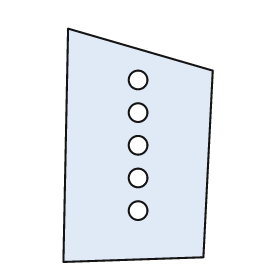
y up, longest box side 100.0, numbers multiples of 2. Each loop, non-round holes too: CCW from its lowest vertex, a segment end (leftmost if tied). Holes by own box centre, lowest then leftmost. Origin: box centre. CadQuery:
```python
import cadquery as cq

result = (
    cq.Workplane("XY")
    .moveTo(-32.0, -50.0)
    .lineTo(28.0, -48.0)
    .lineTo(32.0, 32.0)
    .lineTo(-30.0, 50.0)
    .close()
    .moveTo(0.0, -28.0)
    .circle(4.0)
    .moveTo(0.0, -14.0)
    .circle(4.0)
    .moveTo(0.0, 0.0)
    .circle(4.0)
    .moveTo(0.0, 14.0)
    .circle(4.0)
    .moveTo(0.0, 28.0)
    .circle(4.0)
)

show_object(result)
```